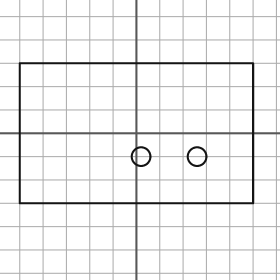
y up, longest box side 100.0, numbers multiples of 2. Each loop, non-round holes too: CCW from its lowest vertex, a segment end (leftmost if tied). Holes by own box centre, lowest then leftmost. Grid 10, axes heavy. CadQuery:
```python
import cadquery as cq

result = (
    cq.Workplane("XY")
    .moveTo(-50.0, -30.0)
    .lineTo(50.0, -30.0)
    .lineTo(50.0, 30.0)
    .lineTo(-50.0, 30.0)
    .close()
    .moveTo(2.0, -10.0)
    .circle(4.0)
    .moveTo(26.0, -10.0)
    .circle(4.0)
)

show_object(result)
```